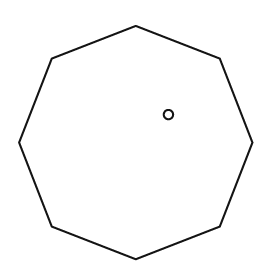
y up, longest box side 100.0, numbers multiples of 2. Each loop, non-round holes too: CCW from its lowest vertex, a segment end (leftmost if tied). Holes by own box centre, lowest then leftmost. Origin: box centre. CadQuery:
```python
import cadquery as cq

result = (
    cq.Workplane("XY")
    .moveTo(0.0, -50.0)
    .lineTo(36.0, -36.0)
    .lineTo(50.0, 0.0)
    .lineTo(36.0, 36.0)
    .lineTo(0.0, 50.0)
    .lineTo(-36.0, 36.0)
    .lineTo(-50.0, 0.0)
    .lineTo(-36.0, -36.0)
    .close()
    .moveTo(14.0, 12.0)
    .circle(2.0)
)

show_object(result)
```